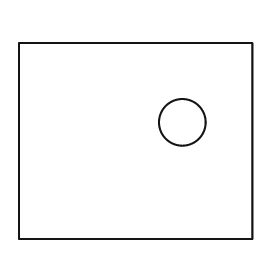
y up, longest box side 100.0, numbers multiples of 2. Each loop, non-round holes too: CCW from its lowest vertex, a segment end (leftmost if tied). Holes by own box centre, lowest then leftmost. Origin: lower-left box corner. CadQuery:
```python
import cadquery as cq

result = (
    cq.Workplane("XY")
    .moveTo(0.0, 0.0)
    .lineTo(100.0, 0.0)
    .lineTo(100.0, 84.0)
    .lineTo(0.0, 84.0)
    .close()
    .moveTo(70.0, 50.0)
    .circle(10.0)
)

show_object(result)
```